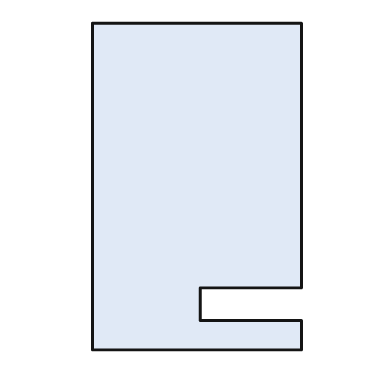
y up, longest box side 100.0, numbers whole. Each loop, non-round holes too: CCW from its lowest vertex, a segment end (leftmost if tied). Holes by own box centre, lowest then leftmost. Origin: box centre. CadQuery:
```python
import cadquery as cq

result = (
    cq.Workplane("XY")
    .moveTo(-32.0, -50.0)
    .lineTo(32.0, -50.0)
    .lineTo(32.0, -41.0)
    .lineTo(1.0, -41.0)
    .lineTo(1.0, -31.0)
    .lineTo(32.0, -31.0)
    .lineTo(32.0, 50.0)
    .lineTo(-32.0, 50.0)
    .close()
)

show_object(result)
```